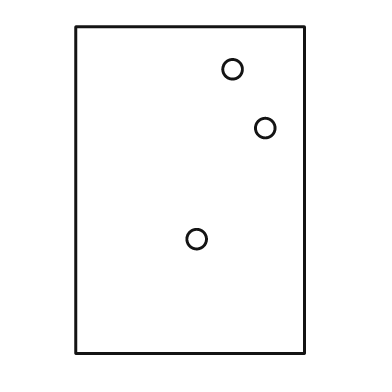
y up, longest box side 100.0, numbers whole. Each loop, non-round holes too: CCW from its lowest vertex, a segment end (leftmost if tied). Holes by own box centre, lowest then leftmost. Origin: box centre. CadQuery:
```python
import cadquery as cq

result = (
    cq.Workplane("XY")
    .moveTo(-35.0, -50.0)
    .lineTo(35.0, -50.0)
    .lineTo(35.0, 50.0)
    .lineTo(-35.0, 50.0)
    .close()
    .moveTo(2.0, -15.0)
    .circle(3.0)
    .moveTo(23.0, 19.0)
    .circle(3.0)
    .moveTo(13.0, 37.0)
    .circle(3.0)
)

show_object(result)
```